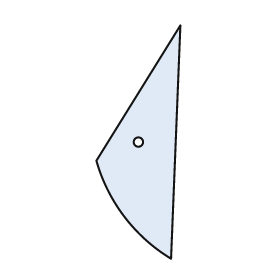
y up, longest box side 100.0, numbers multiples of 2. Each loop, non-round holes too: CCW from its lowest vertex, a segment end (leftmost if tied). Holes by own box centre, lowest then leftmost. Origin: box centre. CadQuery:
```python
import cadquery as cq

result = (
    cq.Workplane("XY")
    .moveTo(14.0, -50.0)
    .lineTo(18.0, 50.0)
    .lineTo(-18.0, -8.0)
    .threePointArc((-6.0, -32.0), (14.0, -50.0))
    .close()
    .moveTo(0.0, 0.0)
    .circle(2.0)
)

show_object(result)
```